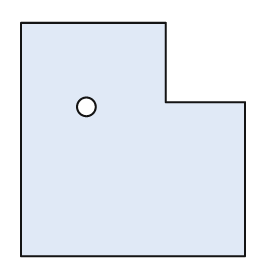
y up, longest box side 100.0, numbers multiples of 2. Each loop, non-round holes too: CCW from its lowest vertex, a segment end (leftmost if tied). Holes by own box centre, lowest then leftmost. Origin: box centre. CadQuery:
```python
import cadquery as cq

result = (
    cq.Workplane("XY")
    .moveTo(-48.0, -50.0)
    .lineTo(48.0, -50.0)
    .lineTo(48.0, 16.0)
    .lineTo(14.0, 16.0)
    .lineTo(14.0, 50.0)
    .lineTo(-48.0, 50.0)
    .close()
    .moveTo(-20.0, 14.0)
    .circle(4.0)
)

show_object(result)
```